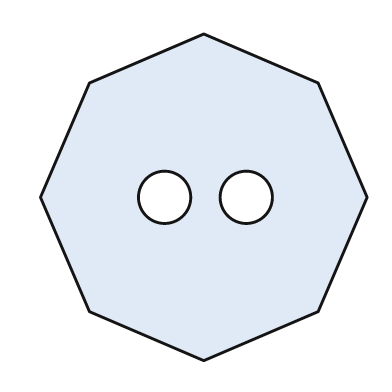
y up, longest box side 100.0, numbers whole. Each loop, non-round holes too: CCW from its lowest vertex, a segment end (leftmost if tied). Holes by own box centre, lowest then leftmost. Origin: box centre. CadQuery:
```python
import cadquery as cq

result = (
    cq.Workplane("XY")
    .moveTo(0.0, -50.0)
    .lineTo(35.0, -35.0)
    .lineTo(50.0, 0.0)
    .lineTo(35.0, 35.0)
    .lineTo(0.0, 50.0)
    .lineTo(-35.0, 35.0)
    .lineTo(-50.0, 0.0)
    .lineTo(-35.0, -35.0)
    .close()
    .moveTo(-12.0, 0.0)
    .circle(8.0)
    .moveTo(13.0, 0.0)
    .circle(8.0)
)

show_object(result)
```